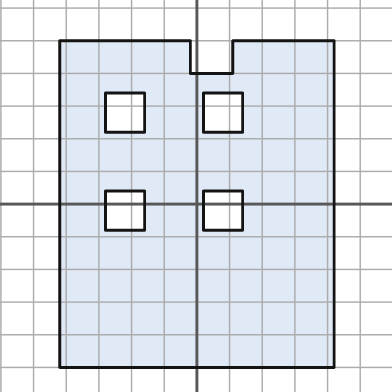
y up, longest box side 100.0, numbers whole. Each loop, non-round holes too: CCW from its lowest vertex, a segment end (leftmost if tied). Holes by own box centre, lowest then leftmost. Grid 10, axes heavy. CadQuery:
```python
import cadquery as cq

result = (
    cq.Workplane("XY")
    .moveTo(-42.0, -50.0)
    .lineTo(42.0, -50.0)
    .lineTo(42.0, 50.0)
    .lineTo(11.0, 50.0)
    .lineTo(11.0, 40.0)
    .lineTo(-2.0, 40.0)
    .lineTo(-2.0, 50.0)
    .lineTo(-42.0, 50.0)
    .close()
    .moveTo(-28.0, -8.0)
    .lineTo(-16.0, -8.0)
    .lineTo(-16.0, 4.0)
    .lineTo(-28.0, 4.0)
    .close()
    .moveTo(2.0, -8.0)
    .lineTo(14.0, -8.0)
    .lineTo(14.0, 4.0)
    .lineTo(2.0, 4.0)
    .close()
    .moveTo(-28.0, 22.0)
    .lineTo(-16.0, 22.0)
    .lineTo(-16.0, 34.0)
    .lineTo(-28.0, 34.0)
    .close()
    .moveTo(2.0, 22.0)
    .lineTo(14.0, 22.0)
    .lineTo(14.0, 34.0)
    .lineTo(2.0, 34.0)
    .close()
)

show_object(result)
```